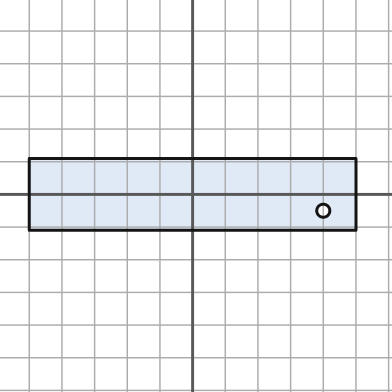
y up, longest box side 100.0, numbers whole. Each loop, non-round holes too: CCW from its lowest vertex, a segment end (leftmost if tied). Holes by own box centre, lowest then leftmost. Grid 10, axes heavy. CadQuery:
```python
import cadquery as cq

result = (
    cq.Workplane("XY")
    .moveTo(-50.0, -11.0)
    .lineTo(50.0, -11.0)
    .lineTo(50.0, 11.0)
    .lineTo(-50.0, 11.0)
    .close()
    .moveTo(40.0, -5.0)
    .circle(2.0)
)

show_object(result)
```